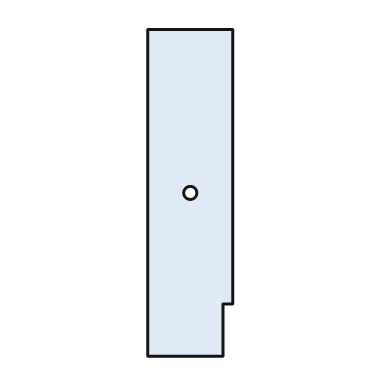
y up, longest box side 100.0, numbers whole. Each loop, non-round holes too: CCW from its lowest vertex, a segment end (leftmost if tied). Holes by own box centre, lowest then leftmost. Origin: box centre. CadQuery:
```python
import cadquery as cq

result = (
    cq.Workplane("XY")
    .moveTo(-13.0, -50.0)
    .lineTo(10.0, -50.0)
    .lineTo(10.0, -34.0)
    .lineTo(13.0, -34.0)
    .lineTo(13.0, 50.0)
    .lineTo(-13.0, 50.0)
    .close()
    .moveTo(0.0, 0.0)
    .circle(2.0)
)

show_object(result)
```